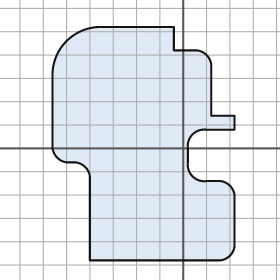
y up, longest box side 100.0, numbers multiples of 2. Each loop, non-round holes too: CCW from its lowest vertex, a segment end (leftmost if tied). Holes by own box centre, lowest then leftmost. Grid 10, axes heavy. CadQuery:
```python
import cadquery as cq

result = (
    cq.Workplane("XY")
    .moveTo(-40.0, -48.0)
    .lineTo(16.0, -48.0)
    .threePointArc((20.0, -46.0), (22.0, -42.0))
    .lineTo(22.0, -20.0)
    .threePointArc((20.0, -16.0), (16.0, -14.0))
    .lineTo(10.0, -14.0)
    .threePointArc((4.0, -12.0), (2.0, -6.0))
    .lineTo(2.0, 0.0)
    .threePointArc((4.0, 6.0), (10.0, 8.0))
    .lineTo(22.0, 8.0)
    .lineTo(22.0, 14.0)
    .lineTo(12.0, 14.0)
    .lineTo(12.0, 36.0)
    .threePointArc((10.0, 40.0), (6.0, 42.0))
    .lineTo(-4.0, 42.0)
    .lineTo(-4.0, 52.0)
    .lineTo(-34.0, 52.0)
    .threePointArc((-50.0, 46.0), (-56.0, 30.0))
    .lineTo(-56.0, 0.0)
    .threePointArc((-54.0, -4.0), (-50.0, -6.0))
    .lineTo(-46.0, -6.0)
    .threePointArc((-42.0, -8.0), (-40.0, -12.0))
    .close()
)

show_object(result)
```